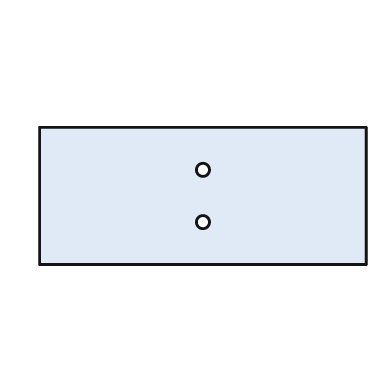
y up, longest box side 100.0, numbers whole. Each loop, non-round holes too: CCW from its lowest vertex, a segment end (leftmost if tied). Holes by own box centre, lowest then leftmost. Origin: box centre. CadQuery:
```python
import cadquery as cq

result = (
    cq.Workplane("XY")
    .moveTo(-50.0, -21.0)
    .lineTo(50.0, -21.0)
    .lineTo(50.0, 21.0)
    .lineTo(-50.0, 21.0)
    .close()
    .moveTo(0.0, -8.0)
    .circle(2.0)
    .moveTo(0.0, 8.0)
    .circle(2.0)
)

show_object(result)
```